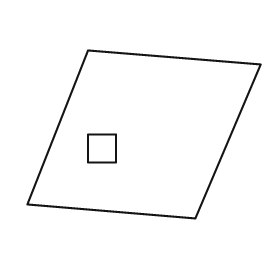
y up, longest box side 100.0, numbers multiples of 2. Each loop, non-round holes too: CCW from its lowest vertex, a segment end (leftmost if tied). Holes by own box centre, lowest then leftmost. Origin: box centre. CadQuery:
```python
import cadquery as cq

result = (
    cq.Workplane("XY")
    .moveTo(22.0, -36.0)
    .lineTo(50.0, 30.0)
    .lineTo(-24.0, 36.0)
    .lineTo(-50.0, -30.0)
    .close()
    .moveTo(-24.0, -12.0)
    .lineTo(-12.0, -12.0)
    .lineTo(-12.0, 0.0)
    .lineTo(-24.0, 0.0)
    .close()
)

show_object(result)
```